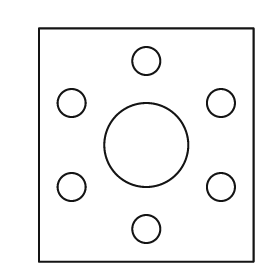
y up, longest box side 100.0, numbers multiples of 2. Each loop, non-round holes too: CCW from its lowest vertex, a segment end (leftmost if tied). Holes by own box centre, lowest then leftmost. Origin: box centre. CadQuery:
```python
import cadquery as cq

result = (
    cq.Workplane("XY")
    .moveTo(-46.0, -50.0)
    .lineTo(46.0, -50.0)
    .lineTo(46.0, 50.0)
    .lineTo(-46.0, 50.0)
    .close()
    .moveTo(0.0, -36.0)
    .circle(6.0)
    .moveTo(-32.0, -18.0)
    .circle(6.0)
    .moveTo(32.0, -18.0)
    .circle(6.0)
    .moveTo(0.0, 0.0)
    .circle(18.0)
    .moveTo(-32.0, 18.0)
    .circle(6.0)
    .moveTo(32.0, 18.0)
    .circle(6.0)
    .moveTo(0.0, 36.0)
    .circle(6.0)
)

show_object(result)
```